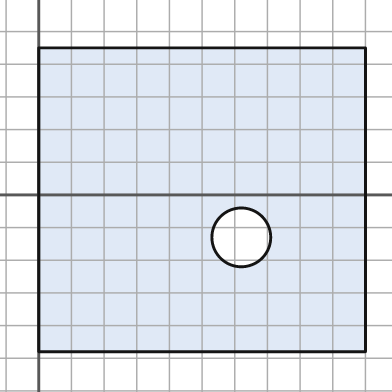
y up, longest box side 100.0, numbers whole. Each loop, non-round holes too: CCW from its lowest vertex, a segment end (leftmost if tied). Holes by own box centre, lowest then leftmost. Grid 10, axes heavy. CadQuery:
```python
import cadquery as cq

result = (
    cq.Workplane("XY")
    .moveTo(0.0, -48.0)
    .lineTo(100.0, -48.0)
    .lineTo(100.0, 45.0)
    .lineTo(0.0, 45.0)
    .close()
    .moveTo(62.0, -13.0)
    .circle(9.0)
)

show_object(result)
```